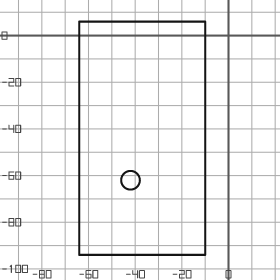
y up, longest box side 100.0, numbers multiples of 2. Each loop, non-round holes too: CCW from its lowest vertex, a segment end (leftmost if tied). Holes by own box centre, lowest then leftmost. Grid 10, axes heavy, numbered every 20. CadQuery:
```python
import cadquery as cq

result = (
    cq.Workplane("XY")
    .moveTo(-64.0, -94.0)
    .lineTo(-10.0, -94.0)
    .lineTo(-10.0, 6.0)
    .lineTo(-64.0, 6.0)
    .close()
    .moveTo(-42.0, -62.0)
    .circle(4.0)
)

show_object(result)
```